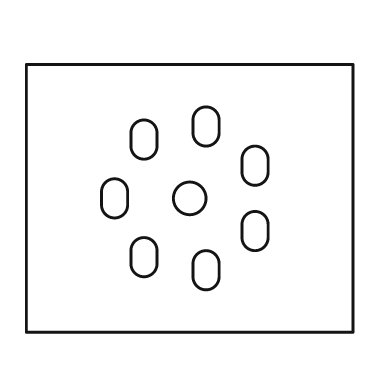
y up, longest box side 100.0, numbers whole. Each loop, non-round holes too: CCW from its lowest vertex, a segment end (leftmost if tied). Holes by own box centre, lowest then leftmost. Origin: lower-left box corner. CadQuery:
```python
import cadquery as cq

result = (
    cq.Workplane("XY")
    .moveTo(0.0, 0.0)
    .lineTo(100.0, 0.0)
    .lineTo(100.0, 82.0)
    .lineTo(0.0, 82.0)
    .close()
    .moveTo(51.0, 17.0)
    .threePointArc((55.0, 13.0), (59.0, 17.0))
    .lineTo(59.0, 21.0)
    .threePointArc((55.0, 25.0), (51.0, 21.0))
    .close()
    .moveTo(32.0, 21.0)
    .threePointArc((36.0, 17.0), (40.0, 21.0))
    .lineTo(40.0, 25.0)
    .threePointArc((36.0, 29.0), (32.0, 25.0))
    .close()
    .moveTo(66.0, 29.0)
    .threePointArc((70.0, 25.0), (74.0, 29.0))
    .lineTo(74.0, 33.0)
    .threePointArc((70.0, 37.0), (66.0, 33.0))
    .close()
    .moveTo(23.0, 39.0)
    .threePointArc((27.0, 35.0), (31.0, 39.0))
    .lineTo(31.0, 43.0)
    .threePointArc((27.0, 47.0), (23.0, 43.0))
    .close()
    .moveTo(50.0, 41.0)
    .circle(5.0)
    .moveTo(66.0, 49.0)
    .threePointArc((70.0, 45.0), (74.0, 49.0))
    .lineTo(74.0, 53.0)
    .threePointArc((70.0, 57.0), (66.0, 53.0))
    .close()
    .moveTo(32.0, 57.0)
    .threePointArc((36.0, 53.0), (40.0, 57.0))
    .lineTo(40.0, 61.0)
    .threePointArc((36.0, 65.0), (32.0, 61.0))
    .close()
    .moveTo(51.0, 61.0)
    .threePointArc((55.0, 57.0), (59.0, 61.0))
    .lineTo(59.0, 65.0)
    .threePointArc((55.0, 69.0), (51.0, 65.0))
    .close()
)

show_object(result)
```